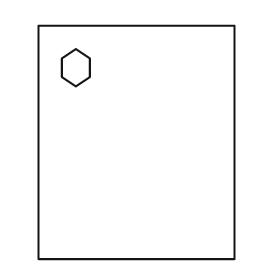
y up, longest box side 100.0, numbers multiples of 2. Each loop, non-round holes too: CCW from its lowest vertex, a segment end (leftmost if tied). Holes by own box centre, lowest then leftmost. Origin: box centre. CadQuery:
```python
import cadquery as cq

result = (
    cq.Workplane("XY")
    .moveTo(-42.0, -50.0)
    .lineTo(42.0, -50.0)
    .lineTo(42.0, 50.0)
    .lineTo(-42.0, 50.0)
    .close()
    .moveTo(-26.0, 24.0)
    .lineTo(-20.0, 28.0)
    .lineTo(-20.0, 36.0)
    .lineTo(-26.0, 40.0)
    .lineTo(-32.0, 36.0)
    .lineTo(-32.0, 28.0)
    .close()
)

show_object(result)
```